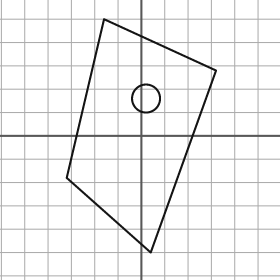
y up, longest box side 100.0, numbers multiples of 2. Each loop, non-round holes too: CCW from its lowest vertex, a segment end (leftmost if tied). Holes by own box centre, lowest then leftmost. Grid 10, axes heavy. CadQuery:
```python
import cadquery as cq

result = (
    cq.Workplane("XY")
    .moveTo(4.0, -50.0)
    .lineTo(32.0, 28.0)
    .lineTo(-16.0, 50.0)
    .lineTo(-32.0, -18.0)
    .close()
    .moveTo(2.0, 16.0)
    .circle(6.0)
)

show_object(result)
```